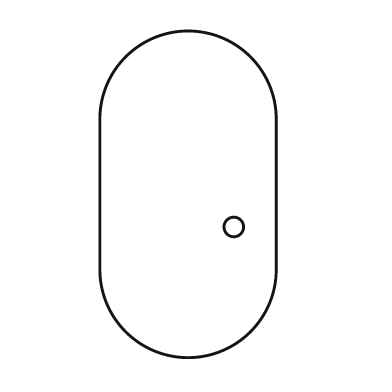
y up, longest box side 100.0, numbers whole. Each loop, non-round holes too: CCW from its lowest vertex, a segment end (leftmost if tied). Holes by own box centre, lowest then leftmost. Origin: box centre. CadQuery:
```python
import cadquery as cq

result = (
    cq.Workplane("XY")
    .moveTo(-27.0, -23.0)
    .threePointArc((0.0, -50.0), (27.0, -23.0))
    .lineTo(27.0, 23.0)
    .threePointArc((0.0, 50.0), (-27.0, 23.0))
    .close()
    .moveTo(14.0, -10.0)
    .circle(3.0)
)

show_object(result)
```